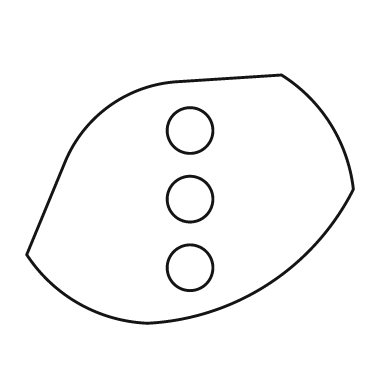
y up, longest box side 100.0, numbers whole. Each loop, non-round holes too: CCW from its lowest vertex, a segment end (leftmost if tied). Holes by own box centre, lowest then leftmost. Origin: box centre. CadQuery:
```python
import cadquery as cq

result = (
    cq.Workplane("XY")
    .moveTo(-13.0, -38.0)
    .threePointArc((24.0, -26.0), (50.0, 3.0))
    .threePointArc((43.0, 23.0), (28.0, 38.0))
    .lineTo(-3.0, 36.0)
    .threePointArc((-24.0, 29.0), (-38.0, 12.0))
    .lineTo(-50.0, -17.0)
    .threePointArc((-34.0, -32.0), (-13.0, -38.0))
    .close()
    .moveTo(0.0, -21.0)
    .circle(7.0)
    .moveTo(0.0, 0.0)
    .circle(7.0)
    .moveTo(0.0, 21.0)
    .circle(7.0)
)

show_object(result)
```